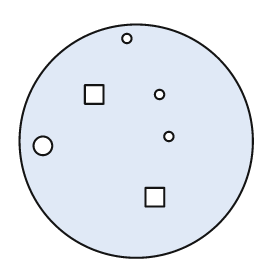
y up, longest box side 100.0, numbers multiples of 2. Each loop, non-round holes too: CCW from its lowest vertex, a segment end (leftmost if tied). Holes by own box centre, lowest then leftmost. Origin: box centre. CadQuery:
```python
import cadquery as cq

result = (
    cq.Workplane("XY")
    .moveTo(0.0, 0.0)
    .circle(50.0)
    .moveTo(4.0, -28.0)
    .lineTo(12.0, -28.0)
    .lineTo(12.0, -20.0)
    .lineTo(4.0, -20.0)
    .close()
    .moveTo(-40.0, -2.0)
    .circle(4.0)
    .moveTo(14.0, 2.0)
    .circle(2.0)
    .moveTo(-22.0, 16.0)
    .lineTo(-14.0, 16.0)
    .lineTo(-14.0, 24.0)
    .lineTo(-22.0, 24.0)
    .close()
    .moveTo(10.0, 20.0)
    .circle(2.0)
    .moveTo(-4.0, 44.0)
    .circle(2.0)
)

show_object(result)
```